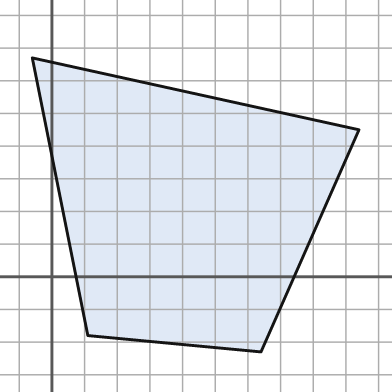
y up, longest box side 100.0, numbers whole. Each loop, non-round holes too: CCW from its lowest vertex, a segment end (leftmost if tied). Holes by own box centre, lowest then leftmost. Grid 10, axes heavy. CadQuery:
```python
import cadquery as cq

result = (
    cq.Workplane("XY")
    .moveTo(64.0, -23.0)
    .lineTo(94.0, 45.0)
    .lineTo(-6.0, 67.0)
    .lineTo(11.0, -18.0)
    .close()
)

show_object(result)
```